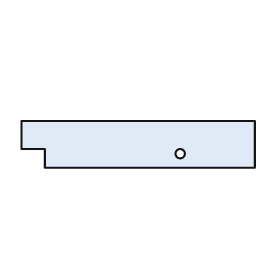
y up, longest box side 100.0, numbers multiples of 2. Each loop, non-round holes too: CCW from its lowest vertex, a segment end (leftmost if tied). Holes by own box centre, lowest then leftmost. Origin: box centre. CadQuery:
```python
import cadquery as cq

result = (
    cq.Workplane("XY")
    .moveTo(-40.0, -10.0)
    .lineTo(50.0, -10.0)
    .lineTo(50.0, 10.0)
    .lineTo(-50.0, 10.0)
    .lineTo(-50.0, -2.0)
    .lineTo(-40.0, -2.0)
    .close()
    .moveTo(18.0, -4.0)
    .circle(2.0)
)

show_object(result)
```